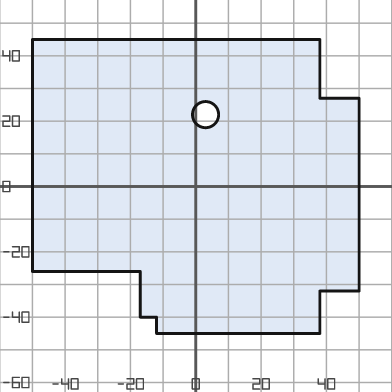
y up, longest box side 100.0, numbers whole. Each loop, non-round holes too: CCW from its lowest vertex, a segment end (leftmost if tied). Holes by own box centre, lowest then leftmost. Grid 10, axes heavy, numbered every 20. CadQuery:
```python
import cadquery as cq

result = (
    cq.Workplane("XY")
    .moveTo(-12.0, -45.0)
    .lineTo(38.0, -45.0)
    .lineTo(38.0, -32.0)
    .lineTo(50.0, -32.0)
    .lineTo(50.0, 27.0)
    .lineTo(38.0, 27.0)
    .lineTo(38.0, 45.0)
    .lineTo(-50.0, 45.0)
    .lineTo(-50.0, -26.0)
    .lineTo(-17.0, -26.0)
    .lineTo(-17.0, -40.0)
    .lineTo(-12.0, -40.0)
    .close()
    .moveTo(3.0, 22.0)
    .circle(4.0)
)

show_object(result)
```